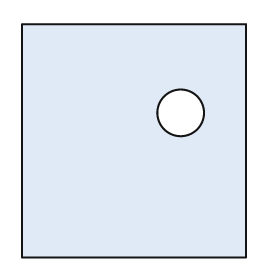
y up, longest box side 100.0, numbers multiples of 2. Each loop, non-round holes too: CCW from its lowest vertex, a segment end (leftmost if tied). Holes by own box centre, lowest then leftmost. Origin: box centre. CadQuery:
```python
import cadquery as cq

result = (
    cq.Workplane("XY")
    .moveTo(-48.0, -50.0)
    .lineTo(48.0, -50.0)
    .lineTo(48.0, 50.0)
    .lineTo(-48.0, 50.0)
    .close()
    .moveTo(20.0, 12.0)
    .circle(10.0)
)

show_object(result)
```